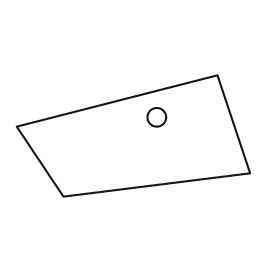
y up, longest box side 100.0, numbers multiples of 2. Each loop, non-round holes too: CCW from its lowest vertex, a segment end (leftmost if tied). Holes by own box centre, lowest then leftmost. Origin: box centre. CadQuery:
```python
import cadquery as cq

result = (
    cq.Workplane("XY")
    .moveTo(-30.0, -26.0)
    .lineTo(50.0, -16.0)
    .lineTo(36.0, 26.0)
    .lineTo(-50.0, 4.0)
    .close()
    .moveTo(10.0, 8.0)
    .circle(4.0)
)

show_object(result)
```